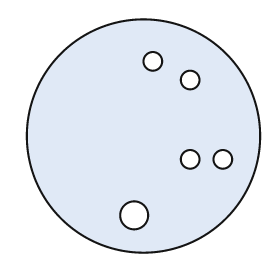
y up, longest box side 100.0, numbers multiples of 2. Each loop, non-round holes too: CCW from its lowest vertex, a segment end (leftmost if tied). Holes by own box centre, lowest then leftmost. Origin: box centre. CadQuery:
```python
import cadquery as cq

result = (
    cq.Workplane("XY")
    .moveTo(0.0, 0.0)
    .circle(50.0)
    .moveTo(-4.0, -34.0)
    .circle(6.0)
    .moveTo(20.0, -10.0)
    .circle(4.0)
    .moveTo(34.0, -10.0)
    .circle(4.0)
    .moveTo(20.0, 24.0)
    .circle(4.0)
    .moveTo(4.0, 32.0)
    .circle(4.0)
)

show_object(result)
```